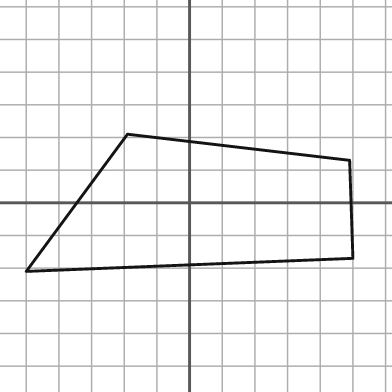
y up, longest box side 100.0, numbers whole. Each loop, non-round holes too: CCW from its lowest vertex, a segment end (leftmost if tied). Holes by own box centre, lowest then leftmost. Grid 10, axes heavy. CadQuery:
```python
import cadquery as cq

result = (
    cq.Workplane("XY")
    .moveTo(-50.0, -21.0)
    .lineTo(50.0, -17.0)
    .lineTo(49.0, 13.0)
    .lineTo(-19.0, 21.0)
    .close()
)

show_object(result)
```